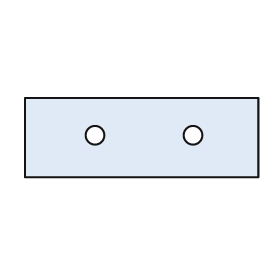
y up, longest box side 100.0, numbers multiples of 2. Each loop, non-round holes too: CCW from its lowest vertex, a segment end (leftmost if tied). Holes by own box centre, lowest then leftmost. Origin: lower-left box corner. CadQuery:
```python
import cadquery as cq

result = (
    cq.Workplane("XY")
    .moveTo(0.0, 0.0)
    .lineTo(100.0, 0.0)
    .lineTo(100.0, 34.0)
    .lineTo(0.0, 34.0)
    .close()
    .moveTo(30.0, 18.0)
    .circle(4.0)
    .moveTo(72.0, 18.0)
    .circle(4.0)
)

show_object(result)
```